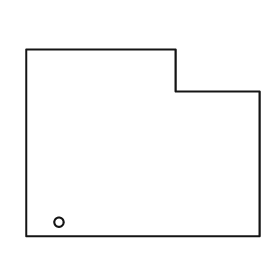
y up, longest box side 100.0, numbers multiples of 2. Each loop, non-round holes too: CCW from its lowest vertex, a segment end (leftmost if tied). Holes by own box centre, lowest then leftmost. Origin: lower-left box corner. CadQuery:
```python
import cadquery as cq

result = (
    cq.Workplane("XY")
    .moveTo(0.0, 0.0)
    .lineTo(100.0, 0.0)
    .lineTo(100.0, 62.0)
    .lineTo(64.0, 62.0)
    .lineTo(64.0, 80.0)
    .lineTo(0.0, 80.0)
    .close()
    .moveTo(14.0, 6.0)
    .circle(2.0)
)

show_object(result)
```